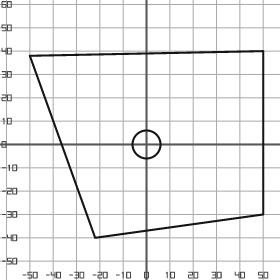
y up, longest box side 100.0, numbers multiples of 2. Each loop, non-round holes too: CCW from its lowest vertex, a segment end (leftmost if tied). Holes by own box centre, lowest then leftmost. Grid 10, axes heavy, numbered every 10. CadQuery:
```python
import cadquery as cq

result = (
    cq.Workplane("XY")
    .moveTo(-22.0, -40.0)
    .lineTo(50.0, -30.0)
    .lineTo(50.0, 40.0)
    .lineTo(-50.0, 38.0)
    .close()
    .moveTo(0.0, 0.0)
    .circle(6.0)
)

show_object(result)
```